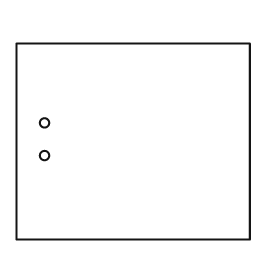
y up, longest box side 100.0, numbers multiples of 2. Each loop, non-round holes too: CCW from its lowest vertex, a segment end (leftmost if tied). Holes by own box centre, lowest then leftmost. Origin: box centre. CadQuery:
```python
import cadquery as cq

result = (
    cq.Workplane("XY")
    .moveTo(-50.0, -42.0)
    .lineTo(50.0, -42.0)
    .lineTo(50.0, 42.0)
    .lineTo(-50.0, 42.0)
    .close()
    .moveTo(-38.0, -6.0)
    .circle(2.0)
    .moveTo(-38.0, 8.0)
    .circle(2.0)
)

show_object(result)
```